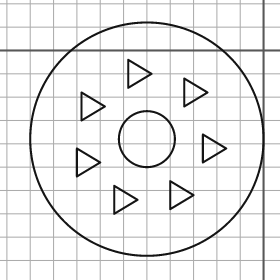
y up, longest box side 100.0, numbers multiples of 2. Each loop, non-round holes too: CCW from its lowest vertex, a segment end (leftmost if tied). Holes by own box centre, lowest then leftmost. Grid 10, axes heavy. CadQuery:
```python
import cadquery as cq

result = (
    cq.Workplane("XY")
    .moveTo(-50.0, -38.0)
    .circle(50.0)
    .moveTo(-64.0, -70.0)
    .lineTo(-54.0, -64.0)
    .lineTo(-64.0, -58.0)
    .close()
    .moveTo(-40.0, -68.0)
    .lineTo(-30.0, -62.0)
    .lineTo(-40.0, -56.0)
    .close()
    .moveTo(-80.0, -54.0)
    .lineTo(-70.0, -48.0)
    .lineTo(-80.0, -42.0)
    .close()
    .moveTo(-26.0, -48.0)
    .lineTo(-16.0, -42.0)
    .lineTo(-26.0, -36.0)
    .close()
    .moveTo(-50.0, -38.0)
    .circle(12.0)
    .moveTo(-78.0, -30.0)
    .lineTo(-68.0, -24.0)
    .lineTo(-78.0, -18.0)
    .close()
    .moveTo(-34.0, -24.0)
    .lineTo(-24.0, -18.0)
    .lineTo(-34.0, -12.0)
    .close()
    .moveTo(-58.0, -16.0)
    .lineTo(-48.0, -10.0)
    .lineTo(-58.0, -4.0)
    .close()
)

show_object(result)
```